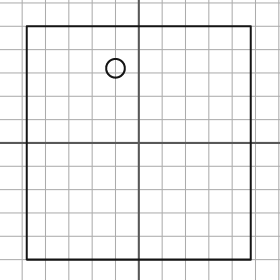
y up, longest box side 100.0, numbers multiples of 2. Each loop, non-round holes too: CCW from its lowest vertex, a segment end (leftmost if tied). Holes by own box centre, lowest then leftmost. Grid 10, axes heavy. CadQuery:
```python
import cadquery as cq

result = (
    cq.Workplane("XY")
    .moveTo(-48.0, -50.0)
    .lineTo(48.0, -50.0)
    .lineTo(48.0, 50.0)
    .lineTo(-48.0, 50.0)
    .close()
    .moveTo(-10.0, 32.0)
    .circle(4.0)
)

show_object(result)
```